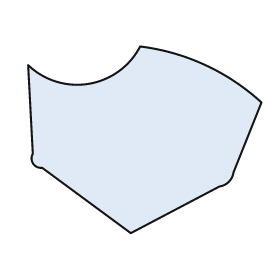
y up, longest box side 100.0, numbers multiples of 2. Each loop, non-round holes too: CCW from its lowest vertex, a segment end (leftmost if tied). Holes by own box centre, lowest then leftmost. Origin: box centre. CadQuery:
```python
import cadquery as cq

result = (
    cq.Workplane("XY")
    .moveTo(-6.0, -40.0)
    .lineTo(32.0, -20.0)
    .threePointArc((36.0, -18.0), (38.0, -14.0))
    .lineTo(50.0, 16.0)
    .threePointArc((26.0, 32.0), (-2.0, 40.0))
    .threePointArc((-24.0, 24.0), (-50.0, 32.0))
    .lineTo(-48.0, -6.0)
    .threePointArc((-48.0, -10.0), (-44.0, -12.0))
    .close()
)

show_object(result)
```